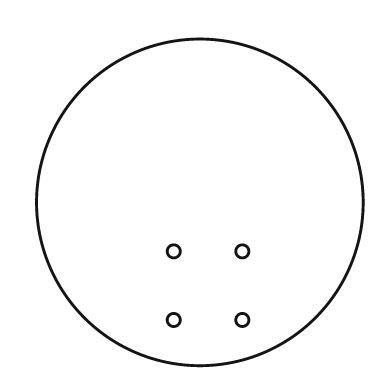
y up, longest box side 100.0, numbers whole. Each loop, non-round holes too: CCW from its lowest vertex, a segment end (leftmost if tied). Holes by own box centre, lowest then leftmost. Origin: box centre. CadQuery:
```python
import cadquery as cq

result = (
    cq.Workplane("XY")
    .moveTo(0.0, 0.0)
    .circle(50.0)
    .moveTo(-8.0, -36.0)
    .circle(2.0)
    .moveTo(13.0, -36.0)
    .circle(2.0)
    .moveTo(-8.0, -15.0)
    .circle(2.0)
    .moveTo(13.0, -15.0)
    .circle(2.0)
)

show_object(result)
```